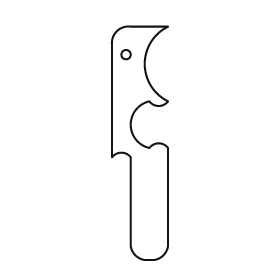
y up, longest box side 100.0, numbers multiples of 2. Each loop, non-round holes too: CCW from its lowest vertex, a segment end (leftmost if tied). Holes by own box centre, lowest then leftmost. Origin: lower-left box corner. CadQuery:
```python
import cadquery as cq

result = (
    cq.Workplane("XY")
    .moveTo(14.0, 0.0)
    .lineTo(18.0, 0.0)
    .threePointArc((22.0, 2.0), (24.0, 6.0))
    .lineTo(24.0, 48.0)
    .threePointArc((20.0, 50.0), (16.0, 48.0))
    .threePointArc((8.0, 58.0), (16.0, 68.0))
    .threePointArc((20.0, 66.0), (24.0, 68.0))
    .threePointArc((14.0, 84.0), (24.0, 100.0))
    .lineTo(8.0, 100.0)
    .threePointArc((2.0, 98.0), (0.0, 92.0))
    .lineTo(0.0, 44.0)
    .threePointArc((4.0, 46.0), (8.0, 44.0))
    .lineTo(8.0, 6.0)
    .threePointArc((10.0, 2.0), (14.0, 0.0))
    .close()
    .moveTo(6.0, 88.0)
    .circle(2.0)
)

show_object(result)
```